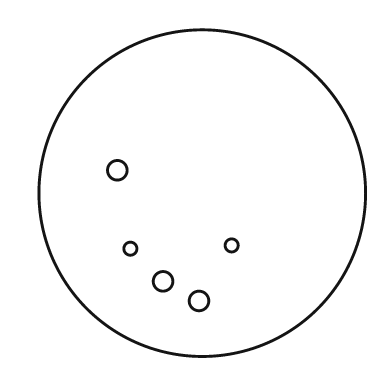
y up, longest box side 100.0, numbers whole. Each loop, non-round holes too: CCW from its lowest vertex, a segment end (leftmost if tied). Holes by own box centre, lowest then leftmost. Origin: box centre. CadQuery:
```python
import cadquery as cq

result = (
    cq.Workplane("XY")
    .moveTo(0.0, 0.0)
    .circle(50.0)
    .moveTo(-1.0, -33.0)
    .circle(3.0)
    .moveTo(-12.0, -27.0)
    .circle(3.0)
    .moveTo(-22.0, -17.0)
    .circle(2.0)
    .moveTo(9.0, -16.0)
    .circle(2.0)
    .moveTo(-26.0, 7.0)
    .circle(3.0)
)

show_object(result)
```